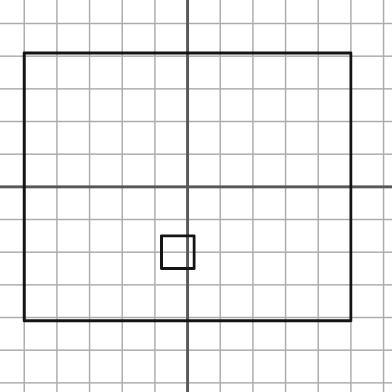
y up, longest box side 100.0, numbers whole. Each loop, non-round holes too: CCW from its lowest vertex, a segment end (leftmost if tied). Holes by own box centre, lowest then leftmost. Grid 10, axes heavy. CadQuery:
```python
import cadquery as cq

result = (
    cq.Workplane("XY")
    .moveTo(-50.0, -41.0)
    .lineTo(50.0, -41.0)
    .lineTo(50.0, 41.0)
    .lineTo(-50.0, 41.0)
    .close()
    .moveTo(-8.0, -25.0)
    .lineTo(2.0, -25.0)
    .lineTo(2.0, -15.0)
    .lineTo(-8.0, -15.0)
    .close()
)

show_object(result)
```